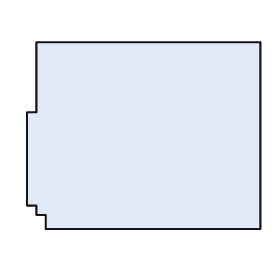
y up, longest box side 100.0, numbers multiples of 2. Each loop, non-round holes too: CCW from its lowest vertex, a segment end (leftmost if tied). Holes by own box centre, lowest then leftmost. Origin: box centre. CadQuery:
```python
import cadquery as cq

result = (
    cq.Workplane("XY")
    .moveTo(-42.0, -40.0)
    .lineTo(50.0, -40.0)
    .lineTo(50.0, 40.0)
    .lineTo(-46.0, 40.0)
    .lineTo(-46.0, 10.0)
    .lineTo(-50.0, 10.0)
    .lineTo(-50.0, -30.0)
    .lineTo(-46.0, -30.0)
    .lineTo(-46.0, -34.0)
    .lineTo(-42.0, -34.0)
    .close()
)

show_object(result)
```